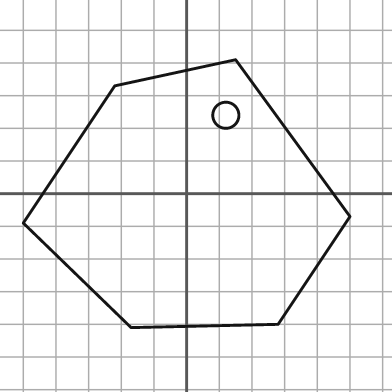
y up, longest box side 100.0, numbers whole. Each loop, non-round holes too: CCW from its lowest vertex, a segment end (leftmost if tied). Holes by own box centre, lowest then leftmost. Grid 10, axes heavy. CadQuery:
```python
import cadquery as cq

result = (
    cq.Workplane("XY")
    .moveTo(-17.0, -41.0)
    .lineTo(28.0, -40.0)
    .lineTo(50.0, -7.0)
    .lineTo(15.0, 41.0)
    .lineTo(-22.0, 33.0)
    .lineTo(-50.0, -9.0)
    .close()
    .moveTo(12.0, 24.0)
    .circle(4.0)
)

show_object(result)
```